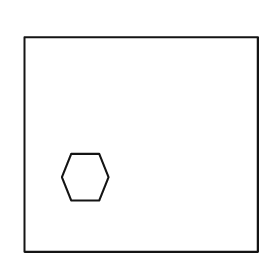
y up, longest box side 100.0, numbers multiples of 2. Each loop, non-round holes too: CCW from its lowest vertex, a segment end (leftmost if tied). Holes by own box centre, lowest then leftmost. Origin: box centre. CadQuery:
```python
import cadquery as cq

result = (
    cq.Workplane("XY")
    .moveTo(-50.0, -46.0)
    .lineTo(50.0, -46.0)
    .lineTo(50.0, 46.0)
    .lineTo(-50.0, 46.0)
    .close()
    .moveTo(-30.0, -24.0)
    .lineTo(-18.0, -24.0)
    .lineTo(-14.0, -14.0)
    .lineTo(-18.0, -4.0)
    .lineTo(-30.0, -4.0)
    .lineTo(-34.0, -14.0)
    .close()
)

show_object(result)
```